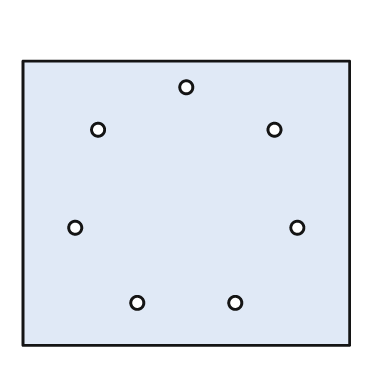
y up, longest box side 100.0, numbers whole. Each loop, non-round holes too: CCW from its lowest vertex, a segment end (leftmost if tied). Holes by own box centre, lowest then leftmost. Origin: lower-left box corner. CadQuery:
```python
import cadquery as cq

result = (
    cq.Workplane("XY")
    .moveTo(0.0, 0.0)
    .lineTo(100.0, 0.0)
    .lineTo(100.0, 87.0)
    .lineTo(0.0, 87.0)
    .close()
    .moveTo(35.0, 13.0)
    .circle(2.0)
    .moveTo(65.0, 13.0)
    .circle(2.0)
    .moveTo(16.0, 36.0)
    .circle(2.0)
    .moveTo(84.0, 36.0)
    .circle(2.0)
    .moveTo(23.0, 66.0)
    .circle(2.0)
    .moveTo(77.0, 66.0)
    .circle(2.0)
    .moveTo(50.0, 79.0)
    .circle(2.0)
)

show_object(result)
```